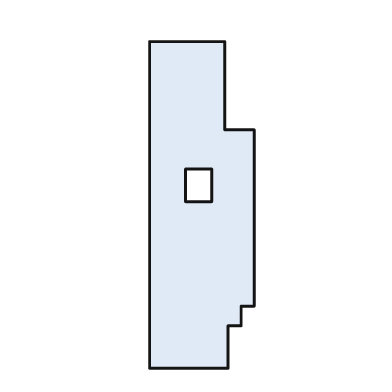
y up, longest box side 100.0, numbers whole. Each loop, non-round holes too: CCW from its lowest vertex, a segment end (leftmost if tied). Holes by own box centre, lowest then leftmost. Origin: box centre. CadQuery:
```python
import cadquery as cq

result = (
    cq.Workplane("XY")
    .moveTo(-16.0, -50.0)
    .lineTo(8.0, -50.0)
    .lineTo(8.0, -37.0)
    .lineTo(12.0, -37.0)
    .lineTo(12.0, -31.0)
    .lineTo(16.0, -31.0)
    .lineTo(16.0, 23.0)
    .lineTo(7.0, 23.0)
    .lineTo(7.0, 50.0)
    .lineTo(-16.0, 50.0)
    .close()
    .moveTo(-5.0, 1.0)
    .lineTo(3.0, 1.0)
    .lineTo(3.0, 11.0)
    .lineTo(-5.0, 11.0)
    .close()
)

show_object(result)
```